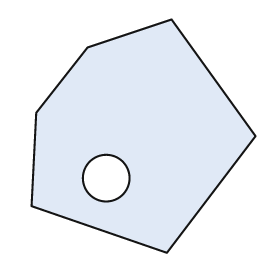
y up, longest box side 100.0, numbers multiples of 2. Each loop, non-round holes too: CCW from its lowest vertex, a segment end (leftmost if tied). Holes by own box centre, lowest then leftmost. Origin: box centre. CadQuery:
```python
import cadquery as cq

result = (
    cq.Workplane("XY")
    .moveTo(10.0, -50.0)
    .lineTo(48.0, 0.0)
    .lineTo(12.0, 50.0)
    .lineTo(-24.0, 38.0)
    .lineTo(-46.0, 10.0)
    .lineTo(-48.0, -30.0)
    .close()
    .moveTo(-16.0, -18.0)
    .circle(10.0)
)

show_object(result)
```